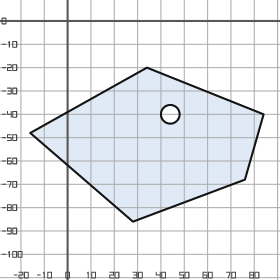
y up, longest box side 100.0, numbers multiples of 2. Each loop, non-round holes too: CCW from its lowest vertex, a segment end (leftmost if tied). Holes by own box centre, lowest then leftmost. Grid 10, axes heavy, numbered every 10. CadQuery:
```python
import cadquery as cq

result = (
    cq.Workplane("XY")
    .moveTo(28.0, -86.0)
    .lineTo(76.0, -68.0)
    .lineTo(84.0, -40.0)
    .lineTo(34.0, -20.0)
    .lineTo(-16.0, -48.0)
    .close()
    .moveTo(44.0, -40.0)
    .circle(4.0)
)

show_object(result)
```